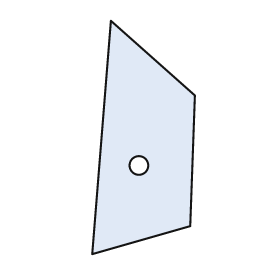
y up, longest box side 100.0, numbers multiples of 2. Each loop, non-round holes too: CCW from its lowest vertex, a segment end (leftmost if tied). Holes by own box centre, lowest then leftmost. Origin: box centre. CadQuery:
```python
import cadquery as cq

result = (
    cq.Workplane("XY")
    .moveTo(-22.0, -50.0)
    .lineTo(20.0, -38.0)
    .lineTo(22.0, 18.0)
    .lineTo(-14.0, 50.0)
    .close()
    .moveTo(-2.0, -12.0)
    .circle(4.0)
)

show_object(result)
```